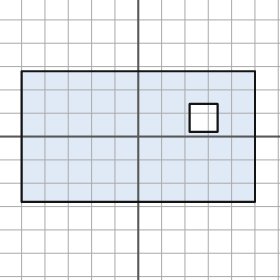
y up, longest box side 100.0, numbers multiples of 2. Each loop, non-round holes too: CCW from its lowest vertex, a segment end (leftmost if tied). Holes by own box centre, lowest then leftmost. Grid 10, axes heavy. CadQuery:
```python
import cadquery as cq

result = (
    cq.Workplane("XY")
    .moveTo(-50.0, -28.0)
    .lineTo(50.0, -28.0)
    .lineTo(50.0, 28.0)
    .lineTo(-50.0, 28.0)
    .close()
    .moveTo(22.0, 2.0)
    .lineTo(34.0, 2.0)
    .lineTo(34.0, 14.0)
    .lineTo(22.0, 14.0)
    .close()
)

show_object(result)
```